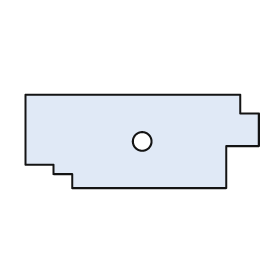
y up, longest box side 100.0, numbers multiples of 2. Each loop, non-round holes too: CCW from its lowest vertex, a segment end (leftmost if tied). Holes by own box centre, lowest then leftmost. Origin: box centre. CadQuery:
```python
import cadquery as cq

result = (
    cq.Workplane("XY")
    .moveTo(-30.0, -20.0)
    .lineTo(36.0, -20.0)
    .lineTo(36.0, -2.0)
    .lineTo(50.0, -2.0)
    .lineTo(50.0, 12.0)
    .lineTo(42.0, 12.0)
    .lineTo(42.0, 20.0)
    .lineTo(-50.0, 20.0)
    .lineTo(-50.0, -10.0)
    .lineTo(-38.0, -10.0)
    .lineTo(-38.0, -14.0)
    .lineTo(-30.0, -14.0)
    .close()
    .moveTo(0.0, 0.0)
    .circle(4.0)
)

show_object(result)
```